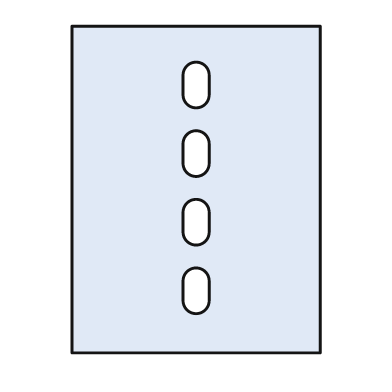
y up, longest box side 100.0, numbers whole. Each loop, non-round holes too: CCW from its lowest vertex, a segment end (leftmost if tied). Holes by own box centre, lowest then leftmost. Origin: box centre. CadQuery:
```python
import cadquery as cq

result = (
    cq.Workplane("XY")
    .moveTo(-38.0, -50.0)
    .lineTo(38.0, -50.0)
    .lineTo(38.0, 50.0)
    .lineTo(-38.0, 50.0)
    .close()
    .moveTo(-4.0, -34.0)
    .threePointArc((0.0, -38.0), (4.0, -34.0))
    .lineTo(4.0, -28.0)
    .threePointArc((0.0, -24.0), (-4.0, -28.0))
    .close()
    .moveTo(-4.0, -13.0)
    .threePointArc((0.0, -17.0), (4.0, -13.0))
    .lineTo(4.0, -7.0)
    .threePointArc((0.0, -3.0), (-4.0, -7.0))
    .close()
    .moveTo(-4.0, 8.0)
    .threePointArc((0.0, 4.0), (4.0, 8.0))
    .lineTo(4.0, 14.0)
    .threePointArc((0.0, 18.0), (-4.0, 14.0))
    .close()
    .moveTo(-4.0, 29.0)
    .threePointArc((0.0, 25.0), (4.0, 29.0))
    .lineTo(4.0, 35.0)
    .threePointArc((0.0, 39.0), (-4.0, 35.0))
    .close()
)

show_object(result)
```